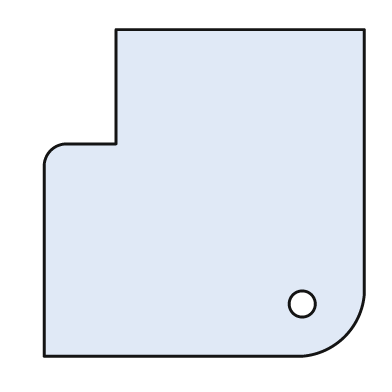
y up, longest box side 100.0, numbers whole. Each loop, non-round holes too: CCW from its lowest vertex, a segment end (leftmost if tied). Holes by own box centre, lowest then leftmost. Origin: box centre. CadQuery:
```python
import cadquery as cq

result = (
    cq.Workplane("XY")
    .moveTo(-49.0, -50.0)
    .lineTo(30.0, -50.0)
    .threePointArc((43.0, -44.0), (49.0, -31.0))
    .lineTo(49.0, 50.0)
    .lineTo(-27.0, 50.0)
    .lineTo(-27.0, 15.0)
    .lineTo(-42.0, 15.0)
    .threePointArc((-47.0, 13.0), (-49.0, 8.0))
    .close()
    .moveTo(30.0, -34.0)
    .circle(4.0)
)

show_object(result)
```